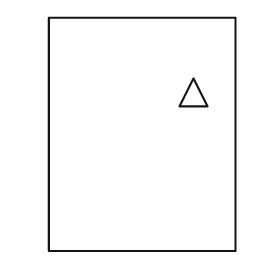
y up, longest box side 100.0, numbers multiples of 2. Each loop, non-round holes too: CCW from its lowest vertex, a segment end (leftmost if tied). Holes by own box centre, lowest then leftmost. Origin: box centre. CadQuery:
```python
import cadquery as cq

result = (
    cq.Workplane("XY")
    .moveTo(-40.0, -50.0)
    .lineTo(40.0, -50.0)
    .lineTo(40.0, 50.0)
    .lineTo(-40.0, 50.0)
    .close()
    .moveTo(16.0, 12.0)
    .lineTo(28.0, 12.0)
    .lineTo(22.0, 24.0)
    .close()
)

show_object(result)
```